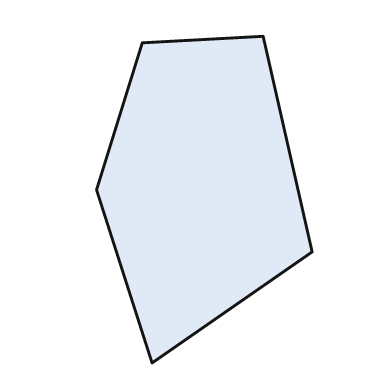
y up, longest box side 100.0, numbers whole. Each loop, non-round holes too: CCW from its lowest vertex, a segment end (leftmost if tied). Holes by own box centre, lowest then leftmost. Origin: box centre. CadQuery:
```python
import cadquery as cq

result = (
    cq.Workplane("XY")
    .moveTo(-16.0, -50.0)
    .lineTo(33.0, -16.0)
    .lineTo(18.0, 50.0)
    .lineTo(-19.0, 48.0)
    .lineTo(-33.0, 3.0)
    .close()
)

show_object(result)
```